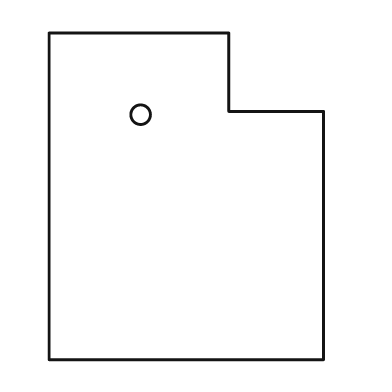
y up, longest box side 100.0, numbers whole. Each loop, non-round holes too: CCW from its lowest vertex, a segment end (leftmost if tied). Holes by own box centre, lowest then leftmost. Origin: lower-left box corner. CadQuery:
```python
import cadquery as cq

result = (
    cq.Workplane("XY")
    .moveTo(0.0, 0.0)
    .lineTo(84.0, 0.0)
    .lineTo(84.0, 76.0)
    .lineTo(55.0, 76.0)
    .lineTo(55.0, 100.0)
    .lineTo(0.0, 100.0)
    .close()
    .moveTo(28.0, 75.0)
    .circle(3.0)
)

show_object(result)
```